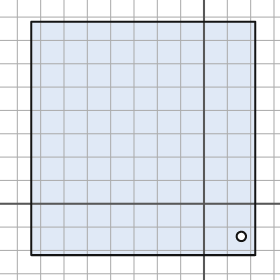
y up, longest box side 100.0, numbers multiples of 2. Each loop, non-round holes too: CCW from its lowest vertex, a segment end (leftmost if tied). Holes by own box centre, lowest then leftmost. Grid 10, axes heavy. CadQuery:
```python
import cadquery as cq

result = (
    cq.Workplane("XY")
    .moveTo(-74.0, -22.0)
    .lineTo(22.0, -22.0)
    .lineTo(22.0, 78.0)
    .lineTo(-74.0, 78.0)
    .close()
    .moveTo(16.0, -14.0)
    .circle(2.0)
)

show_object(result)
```